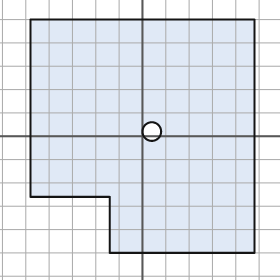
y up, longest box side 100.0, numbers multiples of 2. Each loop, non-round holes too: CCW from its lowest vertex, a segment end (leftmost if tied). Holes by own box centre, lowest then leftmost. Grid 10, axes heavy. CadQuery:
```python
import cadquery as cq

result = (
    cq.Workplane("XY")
    .moveTo(-14.0, -50.0)
    .lineTo(48.0, -50.0)
    .lineTo(48.0, 50.0)
    .lineTo(-48.0, 50.0)
    .lineTo(-48.0, -26.0)
    .lineTo(-14.0, -26.0)
    .close()
    .moveTo(4.0, 2.0)
    .circle(4.0)
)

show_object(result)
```